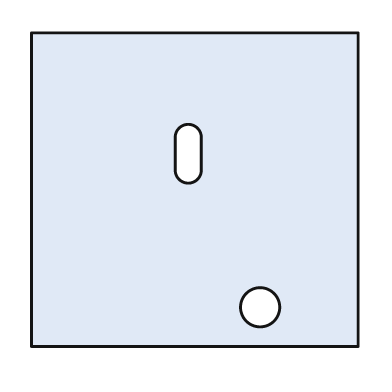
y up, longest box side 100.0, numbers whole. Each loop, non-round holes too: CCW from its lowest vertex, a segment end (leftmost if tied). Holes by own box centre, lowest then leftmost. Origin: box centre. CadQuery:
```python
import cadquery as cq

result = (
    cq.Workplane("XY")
    .moveTo(-50.0, -48.0)
    .lineTo(50.0, -48.0)
    .lineTo(50.0, 48.0)
    .lineTo(-50.0, 48.0)
    .close()
    .moveTo(20.0, -36.0)
    .circle(6.0)
    .moveTo(-6.0, 6.0)
    .threePointArc((-2.0, 2.0), (2.0, 6.0))
    .lineTo(2.0, 16.0)
    .threePointArc((-2.0, 20.0), (-6.0, 16.0))
    .close()
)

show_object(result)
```